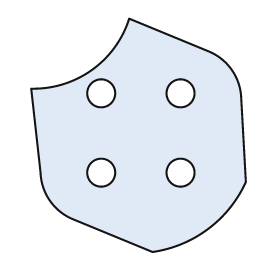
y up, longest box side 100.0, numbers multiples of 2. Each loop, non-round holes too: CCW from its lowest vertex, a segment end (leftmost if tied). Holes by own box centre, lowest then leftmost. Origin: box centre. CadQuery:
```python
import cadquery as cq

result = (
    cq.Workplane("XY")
    .moveTo(6.0, -50.0)
    .threePointArc((30.0, -40.0), (46.0, -20.0))
    .lineTo(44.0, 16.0)
    .threePointArc((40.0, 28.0), (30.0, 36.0))
    .lineTo(-4.0, 50.0)
    .threePointArc((-20.0, 28.0), (-46.0, 20.0))
    .lineTo(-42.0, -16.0)
    .threePointArc((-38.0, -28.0), (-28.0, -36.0))
    .close()
    .moveTo(-16.0, -16.0)
    .circle(6.0)
    .moveTo(18.0, -16.0)
    .circle(6.0)
    .moveTo(-16.0, 18.0)
    .circle(6.0)
    .moveTo(18.0, 18.0)
    .circle(6.0)
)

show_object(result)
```